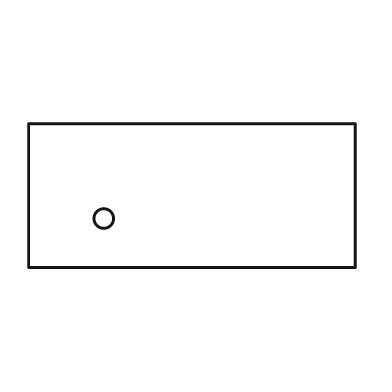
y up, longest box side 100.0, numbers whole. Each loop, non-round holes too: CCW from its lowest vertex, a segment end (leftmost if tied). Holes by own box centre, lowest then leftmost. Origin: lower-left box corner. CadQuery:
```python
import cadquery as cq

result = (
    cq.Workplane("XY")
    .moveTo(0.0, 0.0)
    .lineTo(100.0, 0.0)
    .lineTo(100.0, 44.0)
    .lineTo(0.0, 44.0)
    .close()
    .moveTo(23.0, 15.0)
    .circle(3.0)
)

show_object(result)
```